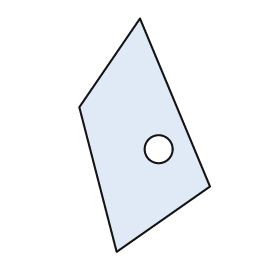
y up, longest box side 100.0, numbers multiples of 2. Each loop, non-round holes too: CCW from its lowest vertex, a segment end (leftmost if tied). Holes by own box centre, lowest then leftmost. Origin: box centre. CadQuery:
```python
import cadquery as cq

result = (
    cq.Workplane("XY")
    .moveTo(-12.0, -50.0)
    .lineTo(28.0, -22.0)
    .lineTo(-2.0, 50.0)
    .lineTo(-28.0, 12.0)
    .close()
    .moveTo(6.0, -6.0)
    .circle(6.0)
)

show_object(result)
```